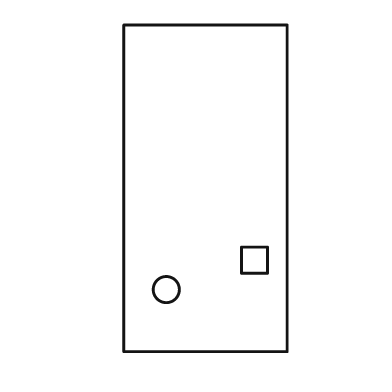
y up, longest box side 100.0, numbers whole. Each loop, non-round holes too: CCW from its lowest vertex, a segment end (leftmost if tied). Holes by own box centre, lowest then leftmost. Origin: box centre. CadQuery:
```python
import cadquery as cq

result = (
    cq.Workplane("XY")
    .moveTo(-25.0, -50.0)
    .lineTo(25.0, -50.0)
    .lineTo(25.0, 50.0)
    .lineTo(-25.0, 50.0)
    .close()
    .moveTo(-12.0, -31.0)
    .circle(4.0)
    .moveTo(11.0, -26.0)
    .lineTo(19.0, -26.0)
    .lineTo(19.0, -18.0)
    .lineTo(11.0, -18.0)
    .close()
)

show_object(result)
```